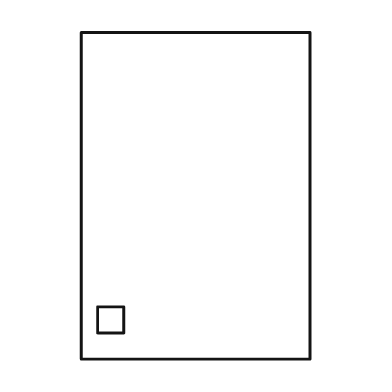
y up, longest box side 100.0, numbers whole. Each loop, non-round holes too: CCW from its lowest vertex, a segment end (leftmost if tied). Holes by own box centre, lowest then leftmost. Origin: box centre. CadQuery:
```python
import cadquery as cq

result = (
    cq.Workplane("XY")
    .moveTo(-35.0, -50.0)
    .lineTo(35.0, -50.0)
    .lineTo(35.0, 50.0)
    .lineTo(-35.0, 50.0)
    .close()
    .moveTo(-30.0, -42.0)
    .lineTo(-22.0, -42.0)
    .lineTo(-22.0, -34.0)
    .lineTo(-30.0, -34.0)
    .close()
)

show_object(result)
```